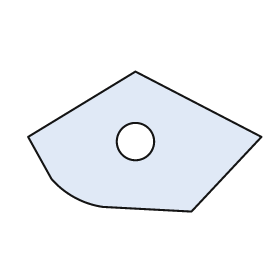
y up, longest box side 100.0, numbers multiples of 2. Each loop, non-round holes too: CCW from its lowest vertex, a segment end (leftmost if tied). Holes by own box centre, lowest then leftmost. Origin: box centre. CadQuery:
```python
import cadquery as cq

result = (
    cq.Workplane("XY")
    .moveTo(20.0, -30.0)
    .lineTo(50.0, 2.0)
    .lineTo(-4.0, 30.0)
    .lineTo(-50.0, 2.0)
    .lineTo(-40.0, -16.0)
    .threePointArc((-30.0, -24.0), (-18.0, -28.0))
    .close()
    .moveTo(-4.0, 0.0)
    .circle(8.0)
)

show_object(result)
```